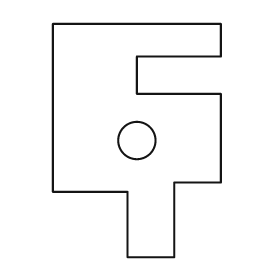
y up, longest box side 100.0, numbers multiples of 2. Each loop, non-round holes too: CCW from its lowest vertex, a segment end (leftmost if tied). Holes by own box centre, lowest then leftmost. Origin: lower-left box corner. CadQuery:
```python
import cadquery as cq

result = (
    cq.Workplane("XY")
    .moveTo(32.0, 0.0)
    .lineTo(52.0, 0.0)
    .lineTo(52.0, 32.0)
    .lineTo(72.0, 32.0)
    .lineTo(72.0, 70.0)
    .lineTo(36.0, 70.0)
    .lineTo(36.0, 86.0)
    .lineTo(72.0, 86.0)
    .lineTo(72.0, 100.0)
    .lineTo(0.0, 100.0)
    .lineTo(0.0, 28.0)
    .lineTo(32.0, 28.0)
    .close()
    .moveTo(36.0, 50.0)
    .circle(8.0)
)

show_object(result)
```